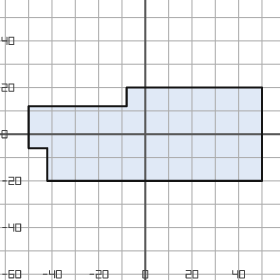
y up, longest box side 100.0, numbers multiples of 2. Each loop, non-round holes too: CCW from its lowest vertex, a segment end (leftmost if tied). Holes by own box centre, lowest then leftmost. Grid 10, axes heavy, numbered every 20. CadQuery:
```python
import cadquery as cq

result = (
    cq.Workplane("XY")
    .moveTo(-42.0, -20.0)
    .lineTo(50.0, -20.0)
    .lineTo(50.0, 20.0)
    .lineTo(-8.0, 20.0)
    .lineTo(-8.0, 12.0)
    .lineTo(-50.0, 12.0)
    .lineTo(-50.0, -6.0)
    .lineTo(-42.0, -6.0)
    .close()
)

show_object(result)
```